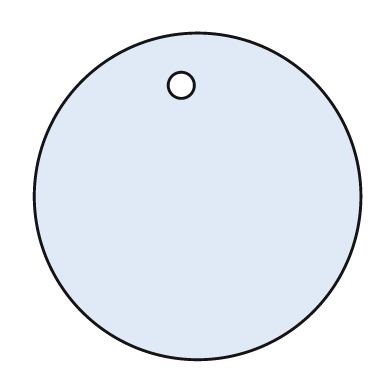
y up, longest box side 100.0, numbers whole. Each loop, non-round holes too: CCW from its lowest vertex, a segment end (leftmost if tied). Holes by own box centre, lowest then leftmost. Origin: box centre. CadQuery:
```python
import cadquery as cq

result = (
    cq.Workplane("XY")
    .moveTo(0.0, 0.0)
    .circle(50.0)
    .moveTo(-5.0, 34.0)
    .circle(4.0)
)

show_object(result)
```